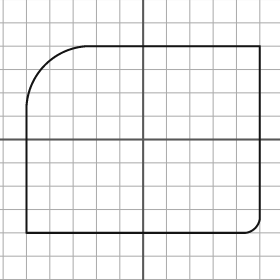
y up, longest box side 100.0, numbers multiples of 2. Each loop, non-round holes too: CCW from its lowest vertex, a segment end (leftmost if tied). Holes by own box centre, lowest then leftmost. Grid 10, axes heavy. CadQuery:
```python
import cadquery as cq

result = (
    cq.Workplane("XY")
    .moveTo(-50.0, -40.0)
    .lineTo(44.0, -40.0)
    .threePointArc((48.0, -38.0), (50.0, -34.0))
    .lineTo(50.0, 40.0)
    .lineTo(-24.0, 40.0)
    .threePointArc((-42.0, 32.0), (-50.0, 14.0))
    .close()
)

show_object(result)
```